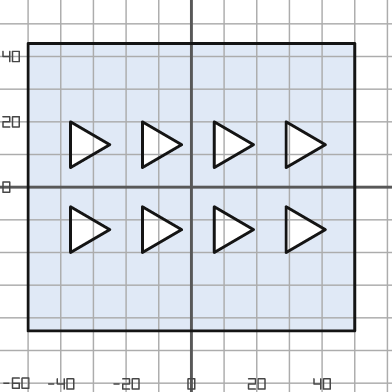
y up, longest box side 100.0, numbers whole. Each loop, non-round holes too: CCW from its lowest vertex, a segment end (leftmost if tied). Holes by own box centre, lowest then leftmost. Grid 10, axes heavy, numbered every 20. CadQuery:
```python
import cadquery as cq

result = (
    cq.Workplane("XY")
    .moveTo(-50.0, -44.0)
    .lineTo(50.0, -44.0)
    .lineTo(50.0, 44.0)
    .lineTo(-50.0, 44.0)
    .close()
    .moveTo(-37.0, -20.0)
    .lineTo(-25.0, -13.0)
    .lineTo(-37.0, -6.0)
    .close()
    .moveTo(-15.0, -20.0)
    .lineTo(-3.0, -13.0)
    .lineTo(-15.0, -6.0)
    .close()
    .moveTo(7.0, -20.0)
    .lineTo(19.0, -13.0)
    .lineTo(7.0, -6.0)
    .close()
    .moveTo(29.0, -20.0)
    .lineTo(41.0, -13.0)
    .lineTo(29.0, -6.0)
    .close()
    .moveTo(-37.0, 6.0)
    .lineTo(-25.0, 13.0)
    .lineTo(-37.0, 20.0)
    .close()
    .moveTo(-15.0, 6.0)
    .lineTo(-3.0, 13.0)
    .lineTo(-15.0, 20.0)
    .close()
    .moveTo(7.0, 6.0)
    .lineTo(19.0, 13.0)
    .lineTo(7.0, 20.0)
    .close()
    .moveTo(29.0, 6.0)
    .lineTo(41.0, 13.0)
    .lineTo(29.0, 20.0)
    .close()
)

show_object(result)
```